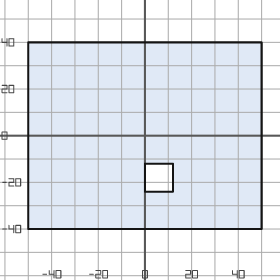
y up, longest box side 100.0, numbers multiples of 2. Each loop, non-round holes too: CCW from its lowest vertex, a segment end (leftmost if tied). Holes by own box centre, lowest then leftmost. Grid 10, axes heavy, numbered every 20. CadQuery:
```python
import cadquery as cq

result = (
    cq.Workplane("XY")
    .moveTo(-50.0, -40.0)
    .lineTo(50.0, -40.0)
    .lineTo(50.0, 40.0)
    .lineTo(-50.0, 40.0)
    .close()
    .moveTo(0.0, -24.0)
    .lineTo(12.0, -24.0)
    .lineTo(12.0, -12.0)
    .lineTo(0.0, -12.0)
    .close()
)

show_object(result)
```